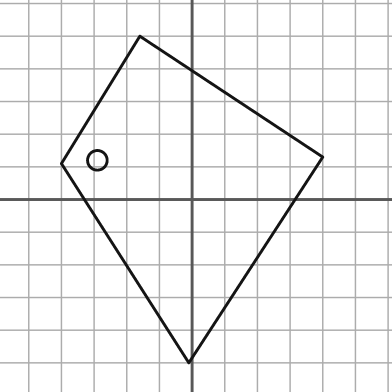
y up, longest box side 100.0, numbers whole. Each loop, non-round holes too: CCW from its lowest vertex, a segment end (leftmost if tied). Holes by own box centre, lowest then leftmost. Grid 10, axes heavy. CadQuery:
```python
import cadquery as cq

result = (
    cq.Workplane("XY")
    .moveTo(-1.0, -50.0)
    .lineTo(40.0, 13.0)
    .lineTo(-16.0, 50.0)
    .lineTo(-40.0, 11.0)
    .close()
    .moveTo(-29.0, 12.0)
    .circle(3.0)
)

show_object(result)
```